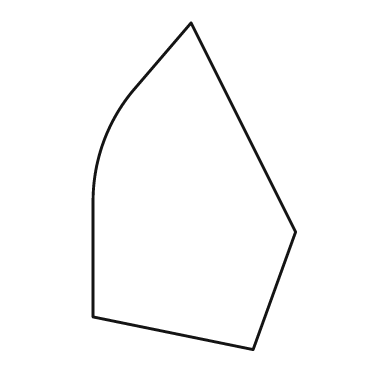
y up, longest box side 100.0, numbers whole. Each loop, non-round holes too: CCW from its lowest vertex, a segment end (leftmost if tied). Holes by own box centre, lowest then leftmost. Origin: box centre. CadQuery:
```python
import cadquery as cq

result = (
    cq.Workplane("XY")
    .moveTo(18.0, -50.0)
    .lineTo(31.0, -14.0)
    .lineTo(-1.0, 50.0)
    .lineTo(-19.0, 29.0)
    .threePointArc((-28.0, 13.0), (-31.0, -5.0))
    .lineTo(-31.0, -40.0)
    .close()
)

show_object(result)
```